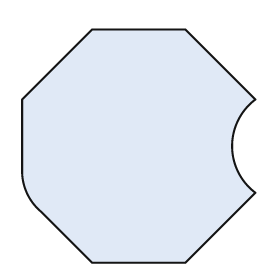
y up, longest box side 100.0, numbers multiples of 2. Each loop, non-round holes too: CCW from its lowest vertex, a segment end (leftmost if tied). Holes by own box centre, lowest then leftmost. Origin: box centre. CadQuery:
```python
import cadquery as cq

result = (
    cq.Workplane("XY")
    .moveTo(-20.0, -50.0)
    .lineTo(20.0, -50.0)
    .lineTo(50.0, -20.0)
    .threePointArc((40.0, 0.0), (50.0, 20.0))
    .lineTo(20.0, 50.0)
    .lineTo(-20.0, 50.0)
    .lineTo(-50.0, 20.0)
    .lineTo(-50.0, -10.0)
    .threePointArc((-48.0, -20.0), (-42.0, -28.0))
    .close()
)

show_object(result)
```